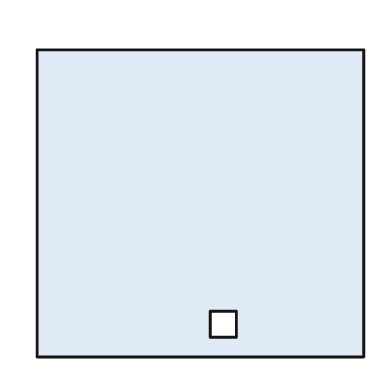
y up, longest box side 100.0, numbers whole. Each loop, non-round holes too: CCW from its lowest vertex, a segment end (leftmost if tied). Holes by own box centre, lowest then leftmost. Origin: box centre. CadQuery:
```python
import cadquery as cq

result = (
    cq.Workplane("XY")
    .moveTo(-50.0, -47.0)
    .lineTo(50.0, -47.0)
    .lineTo(50.0, 47.0)
    .lineTo(-50.0, 47.0)
    .close()
    .moveTo(3.0, -41.0)
    .lineTo(11.0, -41.0)
    .lineTo(11.0, -33.0)
    .lineTo(3.0, -33.0)
    .close()
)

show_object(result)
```